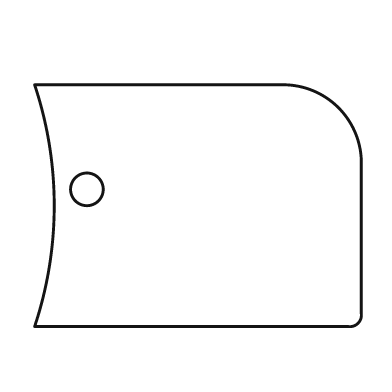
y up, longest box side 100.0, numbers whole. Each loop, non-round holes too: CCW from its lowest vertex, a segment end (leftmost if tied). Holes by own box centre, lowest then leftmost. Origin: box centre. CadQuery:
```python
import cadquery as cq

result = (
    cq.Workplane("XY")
    .moveTo(-50.0, -37.0)
    .lineTo(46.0, -37.0)
    .threePointArc((49.0, -36.0), (50.0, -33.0))
    .lineTo(50.0, 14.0)
    .threePointArc((43.0, 30.0), (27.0, 37.0))
    .lineTo(-50.0, 37.0)
    .threePointArc((-44.0, 0.0), (-50.0, -37.0))
    .close()
    .moveTo(-34.0, 5.0)
    .circle(5.0)
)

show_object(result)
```